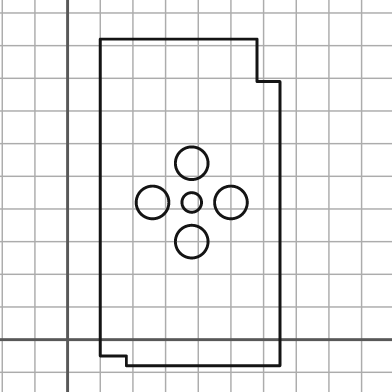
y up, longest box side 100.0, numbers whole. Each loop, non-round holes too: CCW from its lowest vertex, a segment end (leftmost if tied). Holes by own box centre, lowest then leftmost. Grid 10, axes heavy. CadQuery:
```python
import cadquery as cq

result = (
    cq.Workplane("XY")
    .moveTo(18.0, -8.0)
    .lineTo(65.0, -8.0)
    .lineTo(65.0, 79.0)
    .lineTo(58.0, 79.0)
    .lineTo(58.0, 92.0)
    .lineTo(10.0, 92.0)
    .lineTo(10.0, -5.0)
    .lineTo(18.0, -5.0)
    .close()
    .moveTo(38.0, 30.0)
    .circle(5.0)
    .moveTo(26.0, 42.0)
    .circle(5.0)
    .moveTo(38.0, 42.0)
    .circle(3.0)
    .moveTo(50.0, 42.0)
    .circle(5.0)
    .moveTo(38.0, 54.0)
    .circle(5.0)
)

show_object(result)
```